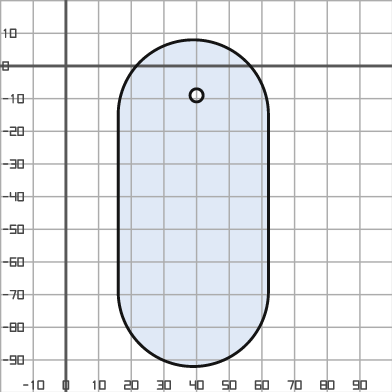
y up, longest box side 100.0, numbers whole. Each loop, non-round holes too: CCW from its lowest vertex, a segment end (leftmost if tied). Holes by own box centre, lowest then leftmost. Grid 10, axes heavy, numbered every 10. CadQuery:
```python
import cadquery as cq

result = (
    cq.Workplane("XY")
    .moveTo(16.0, -69.0)
    .threePointArc((39.0, -92.0), (62.0, -69.0))
    .lineTo(62.0, -15.0)
    .threePointArc((39.0, 8.0), (16.0, -15.0))
    .close()
    .moveTo(40.0, -9.0)
    .circle(2.0)
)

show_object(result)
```